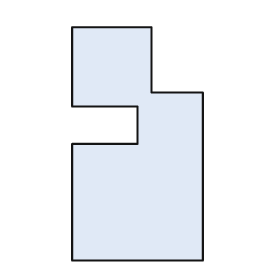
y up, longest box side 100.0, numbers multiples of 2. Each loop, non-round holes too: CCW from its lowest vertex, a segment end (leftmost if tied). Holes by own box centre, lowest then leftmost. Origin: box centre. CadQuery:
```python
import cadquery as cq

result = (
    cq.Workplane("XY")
    .moveTo(-28.0, -50.0)
    .lineTo(28.0, -50.0)
    .lineTo(28.0, 22.0)
    .lineTo(6.0, 22.0)
    .lineTo(6.0, 50.0)
    .lineTo(-28.0, 50.0)
    .lineTo(-28.0, 16.0)
    .lineTo(0.0, 16.0)
    .lineTo(0.0, 0.0)
    .lineTo(-28.0, 0.0)
    .close()
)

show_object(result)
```